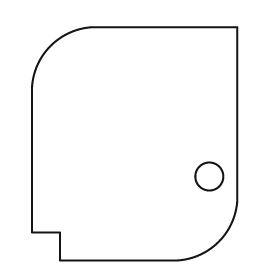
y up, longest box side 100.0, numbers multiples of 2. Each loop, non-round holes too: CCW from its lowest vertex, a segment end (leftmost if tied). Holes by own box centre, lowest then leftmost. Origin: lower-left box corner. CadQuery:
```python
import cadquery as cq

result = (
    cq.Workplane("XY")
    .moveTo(12.0, 0.0)
    .lineTo(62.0, 0.0)
    .threePointArc((80.0, 8.0), (88.0, 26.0))
    .lineTo(88.0, 100.0)
    .lineTo(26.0, 100.0)
    .threePointArc((8.0, 92.0), (0.0, 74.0))
    .lineTo(0.0, 12.0)
    .lineTo(12.0, 12.0)
    .close()
    .moveTo(76.0, 36.0)
    .circle(6.0)
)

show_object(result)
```